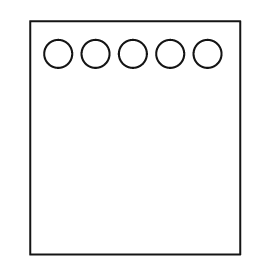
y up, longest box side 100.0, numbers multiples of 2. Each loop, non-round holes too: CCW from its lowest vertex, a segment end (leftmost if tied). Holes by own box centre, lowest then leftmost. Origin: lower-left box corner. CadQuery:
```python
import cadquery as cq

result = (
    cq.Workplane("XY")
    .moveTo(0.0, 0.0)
    .lineTo(90.0, 0.0)
    .lineTo(90.0, 100.0)
    .lineTo(0.0, 100.0)
    .close()
    .moveTo(12.0, 86.0)
    .circle(6.0)
    .moveTo(28.0, 86.0)
    .circle(6.0)
    .moveTo(44.0, 86.0)
    .circle(6.0)
    .moveTo(60.0, 86.0)
    .circle(6.0)
    .moveTo(76.0, 86.0)
    .circle(6.0)
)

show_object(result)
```